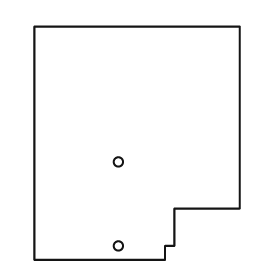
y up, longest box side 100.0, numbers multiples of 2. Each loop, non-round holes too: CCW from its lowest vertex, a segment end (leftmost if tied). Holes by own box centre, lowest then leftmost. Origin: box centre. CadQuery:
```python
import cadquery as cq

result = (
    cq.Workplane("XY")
    .moveTo(-44.0, -50.0)
    .lineTo(12.0, -50.0)
    .lineTo(12.0, -44.0)
    .lineTo(16.0, -44.0)
    .lineTo(16.0, -28.0)
    .lineTo(44.0, -28.0)
    .lineTo(44.0, 50.0)
    .lineTo(-44.0, 50.0)
    .close()
    .moveTo(-8.0, -44.0)
    .circle(2.0)
    .moveTo(-8.0, -8.0)
    .circle(2.0)
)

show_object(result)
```